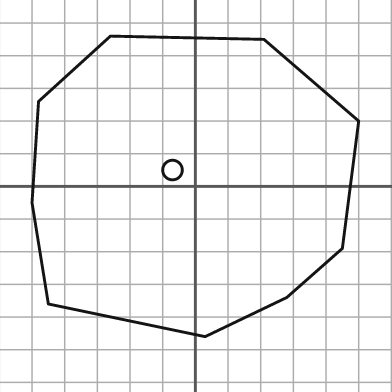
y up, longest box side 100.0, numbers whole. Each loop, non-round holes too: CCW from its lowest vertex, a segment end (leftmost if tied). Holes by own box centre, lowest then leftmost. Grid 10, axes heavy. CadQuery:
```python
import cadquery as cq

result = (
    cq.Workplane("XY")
    .moveTo(3.0, -46.0)
    .lineTo(28.0, -34.0)
    .lineTo(45.0, -19.0)
    .lineTo(50.0, 20.0)
    .lineTo(21.0, 45.0)
    .lineTo(-26.0, 46.0)
    .lineTo(-48.0, 26.0)
    .lineTo(-50.0, -5.0)
    .lineTo(-45.0, -36.0)
    .close()
    .moveTo(-7.0, 5.0)
    .circle(3.0)
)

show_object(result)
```